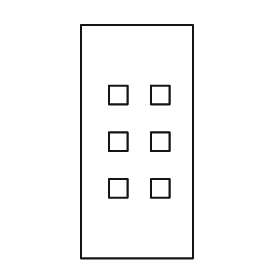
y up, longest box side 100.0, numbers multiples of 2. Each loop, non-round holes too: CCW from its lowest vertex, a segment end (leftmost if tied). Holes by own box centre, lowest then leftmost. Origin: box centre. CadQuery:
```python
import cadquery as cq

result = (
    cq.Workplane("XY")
    .moveTo(-24.0, -50.0)
    .lineTo(24.0, -50.0)
    .lineTo(24.0, 50.0)
    .lineTo(-24.0, 50.0)
    .close()
    .moveTo(-12.0, -24.0)
    .lineTo(-4.0, -24.0)
    .lineTo(-4.0, -16.0)
    .lineTo(-12.0, -16.0)
    .close()
    .moveTo(6.0, -24.0)
    .lineTo(14.0, -24.0)
    .lineTo(14.0, -16.0)
    .lineTo(6.0, -16.0)
    .close()
    .moveTo(-12.0, -4.0)
    .lineTo(-4.0, -4.0)
    .lineTo(-4.0, 4.0)
    .lineTo(-12.0, 4.0)
    .close()
    .moveTo(6.0, -4.0)
    .lineTo(14.0, -4.0)
    .lineTo(14.0, 4.0)
    .lineTo(6.0, 4.0)
    .close()
    .moveTo(-12.0, 16.0)
    .lineTo(-4.0, 16.0)
    .lineTo(-4.0, 24.0)
    .lineTo(-12.0, 24.0)
    .close()
    .moveTo(6.0, 16.0)
    .lineTo(14.0, 16.0)
    .lineTo(14.0, 24.0)
    .lineTo(6.0, 24.0)
    .close()
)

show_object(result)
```